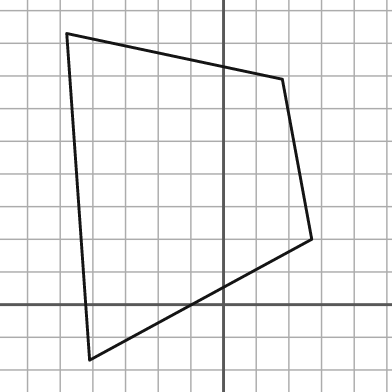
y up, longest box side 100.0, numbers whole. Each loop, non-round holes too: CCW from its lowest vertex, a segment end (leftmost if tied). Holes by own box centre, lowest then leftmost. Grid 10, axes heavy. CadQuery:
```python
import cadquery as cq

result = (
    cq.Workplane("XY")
    .moveTo(-41.0, -17.0)
    .lineTo(27.0, 20.0)
    .lineTo(18.0, 69.0)
    .lineTo(-48.0, 83.0)
    .close()
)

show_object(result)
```